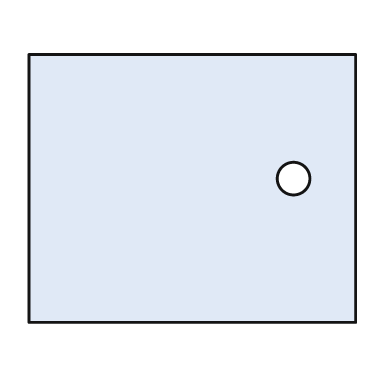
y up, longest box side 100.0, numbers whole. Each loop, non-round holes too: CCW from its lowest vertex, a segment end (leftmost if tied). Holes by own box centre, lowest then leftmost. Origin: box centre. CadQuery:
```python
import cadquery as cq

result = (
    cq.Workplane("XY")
    .moveTo(-50.0, -41.0)
    .lineTo(50.0, -41.0)
    .lineTo(50.0, 41.0)
    .lineTo(-50.0, 41.0)
    .close()
    .moveTo(31.0, 3.0)
    .circle(5.0)
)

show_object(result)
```